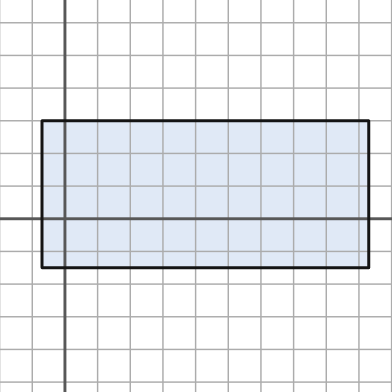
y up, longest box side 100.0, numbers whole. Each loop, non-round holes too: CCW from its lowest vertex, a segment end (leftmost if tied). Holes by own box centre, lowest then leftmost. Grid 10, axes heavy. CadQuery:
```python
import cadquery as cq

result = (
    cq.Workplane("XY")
    .moveTo(-7.0, -15.0)
    .lineTo(93.0, -15.0)
    .lineTo(93.0, 30.0)
    .lineTo(-7.0, 30.0)
    .close()
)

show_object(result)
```